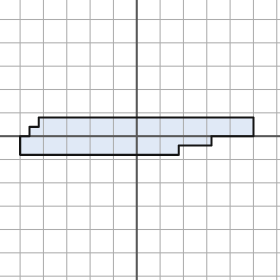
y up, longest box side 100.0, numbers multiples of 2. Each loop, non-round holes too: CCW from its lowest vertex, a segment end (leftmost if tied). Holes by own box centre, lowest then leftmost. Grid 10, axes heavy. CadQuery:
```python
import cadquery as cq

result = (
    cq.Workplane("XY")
    .moveTo(-50.0, -8.0)
    .lineTo(18.0, -8.0)
    .lineTo(18.0, -4.0)
    .lineTo(32.0, -4.0)
    .lineTo(32.0, 0.0)
    .lineTo(50.0, 0.0)
    .lineTo(50.0, 8.0)
    .lineTo(-42.0, 8.0)
    .lineTo(-42.0, 4.0)
    .lineTo(-46.0, 4.0)
    .lineTo(-46.0, 0.0)
    .lineTo(-50.0, 0.0)
    .close()
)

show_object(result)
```